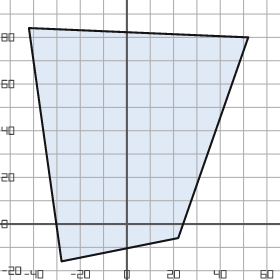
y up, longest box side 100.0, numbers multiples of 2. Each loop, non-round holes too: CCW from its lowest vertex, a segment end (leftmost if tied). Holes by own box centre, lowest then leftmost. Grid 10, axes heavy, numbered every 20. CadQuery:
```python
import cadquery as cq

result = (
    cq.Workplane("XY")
    .moveTo(-28.0, -16.0)
    .lineTo(22.0, -6.0)
    .lineTo(52.0, 80.0)
    .lineTo(-42.0, 84.0)
    .close()
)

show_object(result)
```